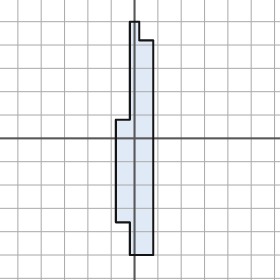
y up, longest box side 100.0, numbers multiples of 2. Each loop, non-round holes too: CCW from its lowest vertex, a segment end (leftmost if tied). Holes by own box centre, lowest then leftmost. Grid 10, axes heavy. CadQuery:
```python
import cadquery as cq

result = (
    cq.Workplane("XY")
    .moveTo(-2.0, -50.0)
    .lineTo(8.0, -50.0)
    .lineTo(8.0, 42.0)
    .lineTo(2.0, 42.0)
    .lineTo(2.0, 50.0)
    .lineTo(-2.0, 50.0)
    .lineTo(-2.0, 8.0)
    .lineTo(-8.0, 8.0)
    .lineTo(-8.0, -36.0)
    .lineTo(-2.0, -36.0)
    .close()
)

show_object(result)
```